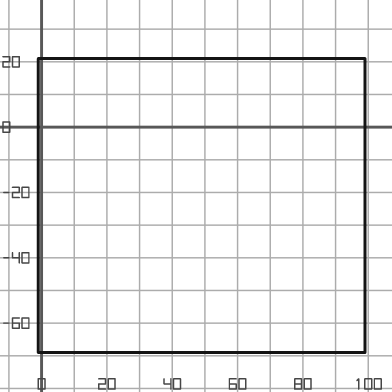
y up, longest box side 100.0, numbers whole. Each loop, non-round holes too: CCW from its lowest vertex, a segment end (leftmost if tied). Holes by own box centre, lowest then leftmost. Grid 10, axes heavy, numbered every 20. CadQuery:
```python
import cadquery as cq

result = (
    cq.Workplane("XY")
    .moveTo(-1.0, -69.0)
    .lineTo(99.0, -69.0)
    .lineTo(99.0, 21.0)
    .lineTo(-1.0, 21.0)
    .close()
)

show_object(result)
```